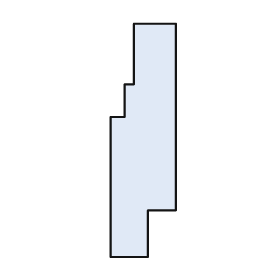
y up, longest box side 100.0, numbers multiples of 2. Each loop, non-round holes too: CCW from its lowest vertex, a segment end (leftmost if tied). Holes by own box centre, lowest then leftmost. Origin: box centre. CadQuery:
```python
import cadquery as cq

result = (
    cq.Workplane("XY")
    .moveTo(-14.0, -50.0)
    .lineTo(2.0, -50.0)
    .lineTo(2.0, -30.0)
    .lineTo(14.0, -30.0)
    .lineTo(14.0, 50.0)
    .lineTo(-4.0, 50.0)
    .lineTo(-4.0, 24.0)
    .lineTo(-8.0, 24.0)
    .lineTo(-8.0, 10.0)
    .lineTo(-14.0, 10.0)
    .close()
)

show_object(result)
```